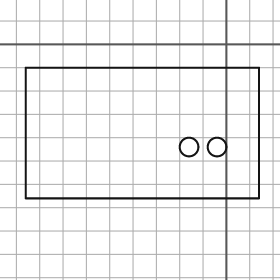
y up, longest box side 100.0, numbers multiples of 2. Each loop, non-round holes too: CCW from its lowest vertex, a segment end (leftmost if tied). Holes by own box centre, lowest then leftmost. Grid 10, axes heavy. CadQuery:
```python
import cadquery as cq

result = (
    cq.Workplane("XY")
    .moveTo(-86.0, -66.0)
    .lineTo(14.0, -66.0)
    .lineTo(14.0, -10.0)
    .lineTo(-86.0, -10.0)
    .close()
    .moveTo(-16.0, -44.0)
    .circle(4.0)
    .moveTo(-4.0, -44.0)
    .circle(4.0)
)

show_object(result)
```